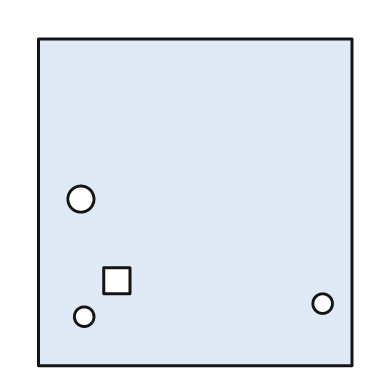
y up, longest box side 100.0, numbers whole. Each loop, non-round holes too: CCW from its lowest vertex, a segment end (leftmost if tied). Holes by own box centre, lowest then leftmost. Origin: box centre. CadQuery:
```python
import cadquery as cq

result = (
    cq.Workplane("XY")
    .moveTo(-48.0, -50.0)
    .lineTo(48.0, -50.0)
    .lineTo(48.0, 50.0)
    .lineTo(-48.0, 50.0)
    .close()
    .moveTo(-34.0, -35.0)
    .circle(3.0)
    .moveTo(39.0, -31.0)
    .circle(3.0)
    .moveTo(-28.0, -28.0)
    .lineTo(-20.0, -28.0)
    .lineTo(-20.0, -20.0)
    .lineTo(-28.0, -20.0)
    .close()
    .moveTo(-35.0, 1.0)
    .circle(4.0)
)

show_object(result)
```